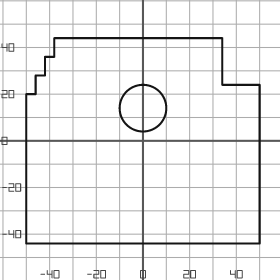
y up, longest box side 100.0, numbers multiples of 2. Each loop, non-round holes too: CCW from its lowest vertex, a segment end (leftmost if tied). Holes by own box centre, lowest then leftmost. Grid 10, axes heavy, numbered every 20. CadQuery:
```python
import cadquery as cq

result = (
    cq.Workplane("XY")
    .moveTo(-50.0, -44.0)
    .lineTo(50.0, -44.0)
    .lineTo(50.0, 24.0)
    .lineTo(34.0, 24.0)
    .lineTo(34.0, 44.0)
    .lineTo(-38.0, 44.0)
    .lineTo(-38.0, 36.0)
    .lineTo(-42.0, 36.0)
    .lineTo(-42.0, 28.0)
    .lineTo(-46.0, 28.0)
    .lineTo(-46.0, 20.0)
    .lineTo(-50.0, 20.0)
    .close()
    .moveTo(0.0, 14.0)
    .circle(10.0)
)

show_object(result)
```